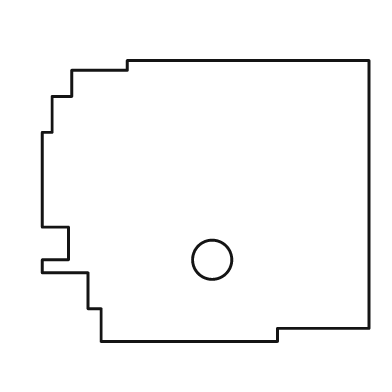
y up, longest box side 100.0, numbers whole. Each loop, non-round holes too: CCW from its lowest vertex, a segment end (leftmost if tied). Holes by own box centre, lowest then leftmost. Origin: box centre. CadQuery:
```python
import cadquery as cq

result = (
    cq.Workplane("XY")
    .moveTo(-32.0, -43.0)
    .lineTo(22.0, -43.0)
    .lineTo(22.0, -39.0)
    .lineTo(50.0, -39.0)
    .lineTo(50.0, 43.0)
    .lineTo(-24.0, 43.0)
    .lineTo(-24.0, 40.0)
    .lineTo(-41.0, 40.0)
    .lineTo(-41.0, 32.0)
    .lineTo(-47.0, 32.0)
    .lineTo(-47.0, 21.0)
    .lineTo(-50.0, 21.0)
    .lineTo(-50.0, -8.0)
    .lineTo(-42.0, -8.0)
    .lineTo(-42.0, -18.0)
    .lineTo(-50.0, -18.0)
    .lineTo(-50.0, -22.0)
    .lineTo(-36.0, -22.0)
    .lineTo(-36.0, -33.0)
    .lineTo(-32.0, -33.0)
    .close()
    .moveTo(2.0, -18.0)
    .circle(6.0)
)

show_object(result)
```